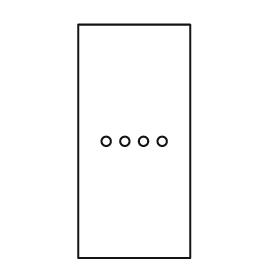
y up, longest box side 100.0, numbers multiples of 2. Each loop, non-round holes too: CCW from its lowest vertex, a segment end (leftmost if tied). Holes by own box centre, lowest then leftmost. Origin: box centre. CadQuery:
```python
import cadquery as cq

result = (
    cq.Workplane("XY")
    .moveTo(-24.0, -50.0)
    .lineTo(24.0, -50.0)
    .lineTo(24.0, 50.0)
    .lineTo(-24.0, 50.0)
    .close()
    .moveTo(-12.0, 0.0)
    .circle(2.0)
    .moveTo(-4.0, 0.0)
    .circle(2.0)
    .moveTo(4.0, 0.0)
    .circle(2.0)
    .moveTo(12.0, 0.0)
    .circle(2.0)
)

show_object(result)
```